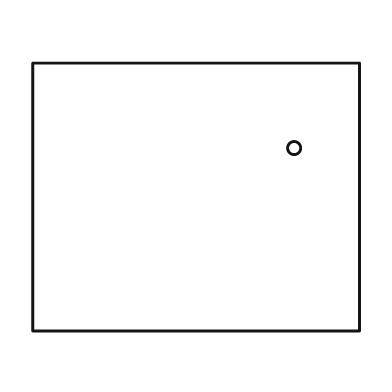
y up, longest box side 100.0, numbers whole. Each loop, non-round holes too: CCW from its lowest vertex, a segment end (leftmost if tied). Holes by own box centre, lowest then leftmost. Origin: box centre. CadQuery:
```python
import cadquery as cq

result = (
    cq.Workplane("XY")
    .moveTo(-50.0, -41.0)
    .lineTo(50.0, -41.0)
    .lineTo(50.0, 41.0)
    .lineTo(-50.0, 41.0)
    .close()
    .moveTo(30.0, 15.0)
    .circle(2.0)
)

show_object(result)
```